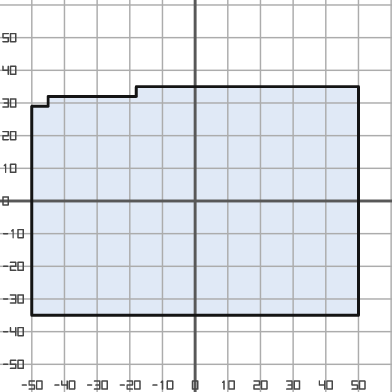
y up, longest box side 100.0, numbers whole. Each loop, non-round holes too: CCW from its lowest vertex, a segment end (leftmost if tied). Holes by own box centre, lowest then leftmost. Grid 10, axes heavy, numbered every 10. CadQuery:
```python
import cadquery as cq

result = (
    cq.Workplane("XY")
    .moveTo(-50.0, -35.0)
    .lineTo(50.0, -35.0)
    .lineTo(50.0, 35.0)
    .lineTo(-18.0, 35.0)
    .lineTo(-18.0, 32.0)
    .lineTo(-45.0, 32.0)
    .lineTo(-45.0, 29.0)
    .lineTo(-50.0, 29.0)
    .close()
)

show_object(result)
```